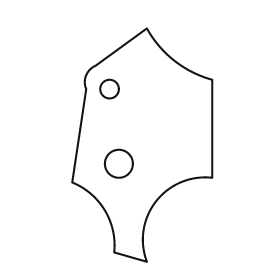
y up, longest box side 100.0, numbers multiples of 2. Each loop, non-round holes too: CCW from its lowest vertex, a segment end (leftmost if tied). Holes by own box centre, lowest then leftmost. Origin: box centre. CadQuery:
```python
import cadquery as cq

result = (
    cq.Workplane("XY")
    .moveTo(2.0, -50.0)
    .threePointArc((6.0, -24.0), (30.0, -14.0))
    .lineTo(30.0, 28.0)
    .threePointArc((14.0, 36.0), (2.0, 50.0))
    .lineTo(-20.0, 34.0)
    .threePointArc((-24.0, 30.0), (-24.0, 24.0))
    .lineTo(-30.0, -16.0)
    .threePointArc((-16.0, -28.0), (-12.0, -46.0))
    .close()
    .moveTo(-10.0, -8.0)
    .circle(6.0)
    .moveTo(-14.0, 24.0)
    .circle(4.0)
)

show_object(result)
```